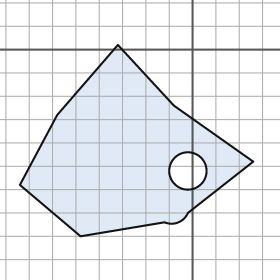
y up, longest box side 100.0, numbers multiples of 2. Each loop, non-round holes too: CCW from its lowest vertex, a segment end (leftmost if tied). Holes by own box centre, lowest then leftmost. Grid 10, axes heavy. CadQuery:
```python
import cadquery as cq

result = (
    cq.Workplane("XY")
    .moveTo(-48.0, -80.0)
    .lineTo(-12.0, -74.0)
    .threePointArc((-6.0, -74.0), (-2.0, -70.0))
    .lineTo(26.0, -48.0)
    .lineTo(-8.0, -24.0)
    .lineTo(-32.0, 2.0)
    .lineTo(-58.0, -28.0)
    .lineTo(-74.0, -58.0)
    .close()
    .moveTo(-2.0, -52.0)
    .circle(8.0)
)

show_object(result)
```